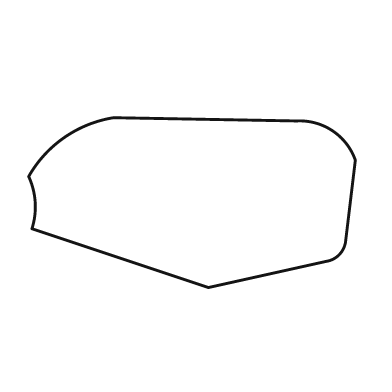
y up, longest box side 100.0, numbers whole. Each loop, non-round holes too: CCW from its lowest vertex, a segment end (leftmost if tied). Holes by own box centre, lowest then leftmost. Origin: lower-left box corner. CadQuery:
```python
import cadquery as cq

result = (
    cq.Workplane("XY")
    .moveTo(55.0, 0.0)
    .lineTo(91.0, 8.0)
    .threePointArc((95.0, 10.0), (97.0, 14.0))
    .lineTo(100.0, 39.0)
    .threePointArc((93.0, 48.0), (82.0, 51.0))
    .lineTo(26.0, 52.0)
    .threePointArc((11.0, 46.0), (0.0, 34.0))
    .threePointArc((2.0, 26.0), (1.0, 18.0))
    .close()
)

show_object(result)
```